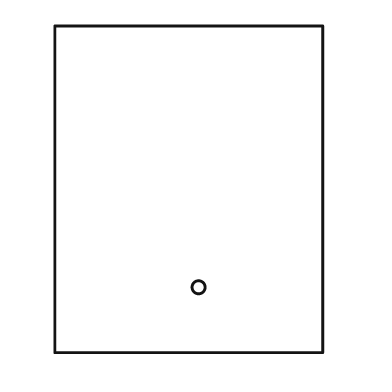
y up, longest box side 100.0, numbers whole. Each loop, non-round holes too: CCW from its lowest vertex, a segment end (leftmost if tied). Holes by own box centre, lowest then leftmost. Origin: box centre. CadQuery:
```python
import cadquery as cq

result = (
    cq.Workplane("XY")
    .moveTo(-41.0, -50.0)
    .lineTo(41.0, -50.0)
    .lineTo(41.0, 50.0)
    .lineTo(-41.0, 50.0)
    .close()
    .moveTo(3.0, -30.0)
    .circle(2.0)
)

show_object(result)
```